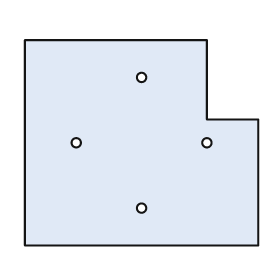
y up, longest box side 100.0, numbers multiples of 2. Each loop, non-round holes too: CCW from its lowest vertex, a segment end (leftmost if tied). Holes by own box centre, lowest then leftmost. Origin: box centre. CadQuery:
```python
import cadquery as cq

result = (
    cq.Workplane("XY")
    .moveTo(-50.0, -44.0)
    .lineTo(50.0, -44.0)
    .lineTo(50.0, 10.0)
    .lineTo(28.0, 10.0)
    .lineTo(28.0, 44.0)
    .lineTo(-50.0, 44.0)
    .close()
    .moveTo(0.0, -28.0)
    .circle(2.0)
    .moveTo(-28.0, 0.0)
    .circle(2.0)
    .moveTo(28.0, 0.0)
    .circle(2.0)
    .moveTo(0.0, 28.0)
    .circle(2.0)
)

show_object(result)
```